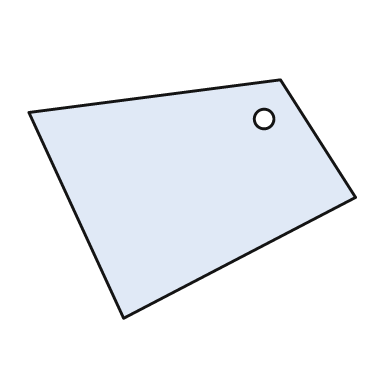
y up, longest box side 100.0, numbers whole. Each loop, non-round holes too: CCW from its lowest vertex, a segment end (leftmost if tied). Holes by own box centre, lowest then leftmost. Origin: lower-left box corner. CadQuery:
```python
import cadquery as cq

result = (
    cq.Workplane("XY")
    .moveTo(29.0, 0.0)
    .lineTo(100.0, 37.0)
    .lineTo(77.0, 73.0)
    .lineTo(0.0, 63.0)
    .close()
    .moveTo(72.0, 61.0)
    .circle(3.0)
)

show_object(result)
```